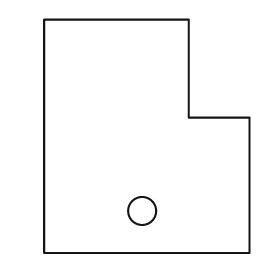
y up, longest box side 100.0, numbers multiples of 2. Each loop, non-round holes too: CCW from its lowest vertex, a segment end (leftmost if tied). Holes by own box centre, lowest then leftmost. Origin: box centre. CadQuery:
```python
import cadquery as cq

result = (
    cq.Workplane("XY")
    .moveTo(-44.0, -50.0)
    .lineTo(44.0, -50.0)
    .lineTo(44.0, 8.0)
    .lineTo(18.0, 8.0)
    .lineTo(18.0, 50.0)
    .lineTo(-44.0, 50.0)
    .close()
    .moveTo(-2.0, -32.0)
    .circle(6.0)
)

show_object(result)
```